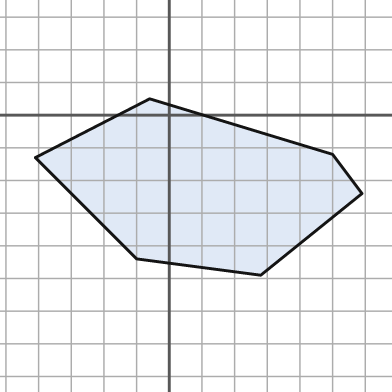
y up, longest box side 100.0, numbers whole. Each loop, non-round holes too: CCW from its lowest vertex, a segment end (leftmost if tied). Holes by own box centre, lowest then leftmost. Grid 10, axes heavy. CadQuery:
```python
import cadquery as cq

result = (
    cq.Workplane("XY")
    .moveTo(28.0, -49.0)
    .lineTo(59.0, -24.0)
    .lineTo(50.0, -12.0)
    .lineTo(-6.0, 5.0)
    .lineTo(-41.0, -13.0)
    .lineTo(-10.0, -44.0)
    .close()
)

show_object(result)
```